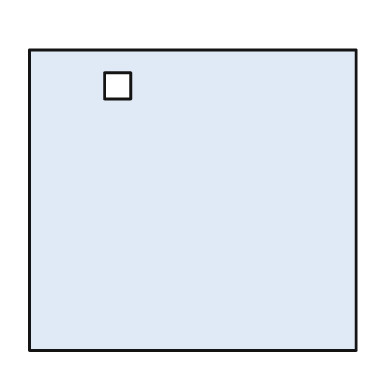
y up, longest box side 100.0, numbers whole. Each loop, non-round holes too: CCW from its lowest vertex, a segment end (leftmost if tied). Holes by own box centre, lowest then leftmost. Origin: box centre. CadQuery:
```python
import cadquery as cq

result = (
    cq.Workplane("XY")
    .moveTo(-50.0, -46.0)
    .lineTo(50.0, -46.0)
    .lineTo(50.0, 46.0)
    .lineTo(-50.0, 46.0)
    .close()
    .moveTo(-27.0, 31.0)
    .lineTo(-19.0, 31.0)
    .lineTo(-19.0, 39.0)
    .lineTo(-27.0, 39.0)
    .close()
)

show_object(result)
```